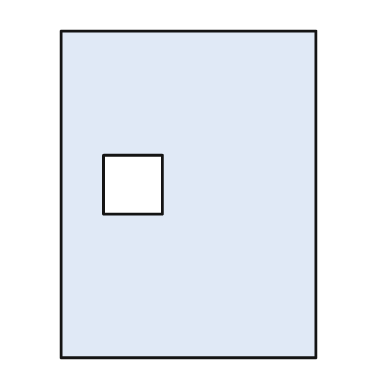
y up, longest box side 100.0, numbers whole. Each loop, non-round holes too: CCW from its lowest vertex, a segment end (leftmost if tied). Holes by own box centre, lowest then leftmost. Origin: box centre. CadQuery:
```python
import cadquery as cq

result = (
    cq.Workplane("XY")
    .moveTo(-39.0, -50.0)
    .lineTo(39.0, -50.0)
    .lineTo(39.0, 50.0)
    .lineTo(-39.0, 50.0)
    .close()
    .moveTo(-26.0, -6.0)
    .lineTo(-8.0, -6.0)
    .lineTo(-8.0, 12.0)
    .lineTo(-26.0, 12.0)
    .close()
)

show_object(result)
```